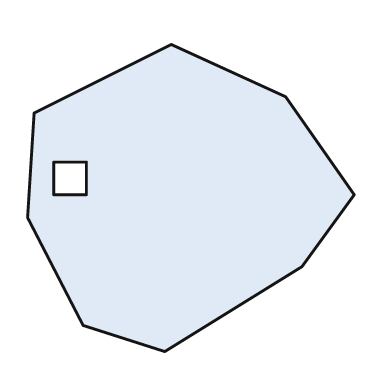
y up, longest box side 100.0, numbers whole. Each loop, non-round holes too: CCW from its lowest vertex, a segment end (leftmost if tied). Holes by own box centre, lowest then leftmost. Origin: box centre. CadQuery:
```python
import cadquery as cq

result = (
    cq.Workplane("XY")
    .moveTo(-8.0, -47.0)
    .lineTo(34.0, -21.0)
    .lineTo(50.0, 1.0)
    .lineTo(29.0, 31.0)
    .lineTo(-6.0, 47.0)
    .lineTo(-48.0, 26.0)
    .lineTo(-50.0, -6.0)
    .lineTo(-33.0, -39.0)
    .close()
    .moveTo(-42.0, 1.0)
    .lineTo(-32.0, 1.0)
    .lineTo(-32.0, 11.0)
    .lineTo(-42.0, 11.0)
    .close()
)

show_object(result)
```